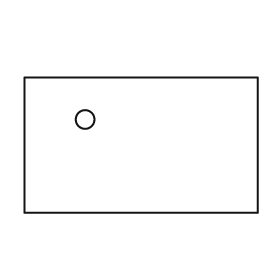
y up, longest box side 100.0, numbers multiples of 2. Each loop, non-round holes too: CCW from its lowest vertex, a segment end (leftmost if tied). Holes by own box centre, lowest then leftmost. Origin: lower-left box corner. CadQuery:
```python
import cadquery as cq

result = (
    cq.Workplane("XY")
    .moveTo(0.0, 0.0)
    .lineTo(100.0, 0.0)
    .lineTo(100.0, 58.0)
    .lineTo(0.0, 58.0)
    .close()
    .moveTo(26.0, 40.0)
    .circle(4.0)
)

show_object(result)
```